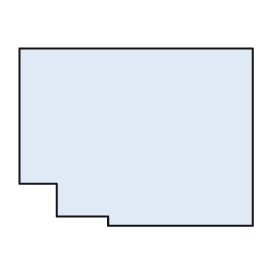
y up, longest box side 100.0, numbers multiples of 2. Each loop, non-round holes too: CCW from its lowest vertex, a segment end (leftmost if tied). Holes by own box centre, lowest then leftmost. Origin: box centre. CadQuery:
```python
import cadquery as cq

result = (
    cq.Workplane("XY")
    .moveTo(-12.0, -38.0)
    .lineTo(50.0, -38.0)
    .lineTo(50.0, 38.0)
    .lineTo(-50.0, 38.0)
    .lineTo(-50.0, -20.0)
    .lineTo(-34.0, -20.0)
    .lineTo(-34.0, -34.0)
    .lineTo(-12.0, -34.0)
    .close()
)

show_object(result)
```